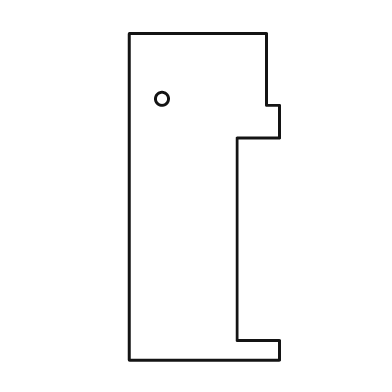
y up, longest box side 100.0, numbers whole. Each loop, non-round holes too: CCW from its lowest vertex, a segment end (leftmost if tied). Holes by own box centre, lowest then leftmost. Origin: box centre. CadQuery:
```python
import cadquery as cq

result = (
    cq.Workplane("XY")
    .moveTo(-23.0, -50.0)
    .lineTo(23.0, -50.0)
    .lineTo(23.0, -44.0)
    .lineTo(10.0, -44.0)
    .lineTo(10.0, 18.0)
    .lineTo(23.0, 18.0)
    .lineTo(23.0, 28.0)
    .lineTo(19.0, 28.0)
    .lineTo(19.0, 50.0)
    .lineTo(-23.0, 50.0)
    .close()
    .moveTo(-13.0, 30.0)
    .circle(2.0)
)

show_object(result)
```